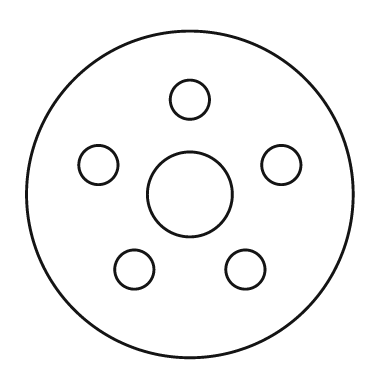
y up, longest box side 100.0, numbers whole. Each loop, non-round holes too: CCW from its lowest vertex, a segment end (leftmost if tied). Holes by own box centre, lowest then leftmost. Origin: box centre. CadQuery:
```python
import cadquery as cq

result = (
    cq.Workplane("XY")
    .moveTo(0.0, 0.0)
    .circle(50.0)
    .moveTo(-17.0, -23.0)
    .circle(6.0)
    .moveTo(17.0, -23.0)
    .circle(6.0)
    .moveTo(0.0, 0.0)
    .circle(13.0)
    .moveTo(-28.0, 9.0)
    .circle(6.0)
    .moveTo(28.0, 9.0)
    .circle(6.0)
    .moveTo(0.0, 29.0)
    .circle(6.0)
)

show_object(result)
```